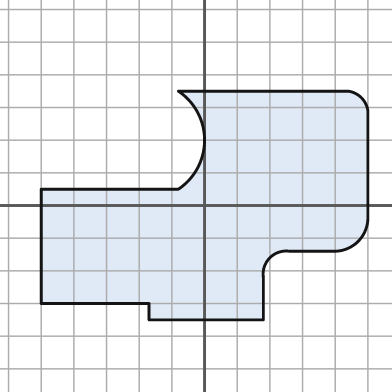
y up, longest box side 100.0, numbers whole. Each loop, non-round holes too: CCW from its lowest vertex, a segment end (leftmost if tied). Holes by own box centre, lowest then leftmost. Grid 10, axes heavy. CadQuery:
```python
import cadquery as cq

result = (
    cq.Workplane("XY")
    .moveTo(-17.0, -35.0)
    .lineTo(18.0, -35.0)
    .lineTo(18.0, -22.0)
    .threePointArc((20.0, -16.0), (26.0, -14.0))
    .lineTo(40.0, -14.0)
    .threePointArc((47.0, -11.0), (50.0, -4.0))
    .lineTo(50.0, 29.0)
    .threePointArc((48.0, 33.0), (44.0, 35.0))
    .lineTo(-8.0, 35.0)
    .threePointArc((0.0, 20.0), (-8.0, 5.0))
    .lineTo(-50.0, 5.0)
    .lineTo(-50.0, -30.0)
    .lineTo(-17.0, -30.0)
    .close()
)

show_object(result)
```